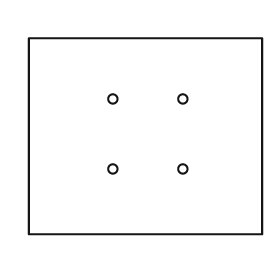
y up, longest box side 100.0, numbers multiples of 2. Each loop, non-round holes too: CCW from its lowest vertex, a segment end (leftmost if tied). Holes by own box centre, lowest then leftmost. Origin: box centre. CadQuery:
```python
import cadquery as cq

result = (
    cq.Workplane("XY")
    .moveTo(-50.0, -42.0)
    .lineTo(50.0, -42.0)
    .lineTo(50.0, 42.0)
    .lineTo(-50.0, 42.0)
    .close()
    .moveTo(-14.0, -14.0)
    .circle(2.0)
    .moveTo(16.0, -14.0)
    .circle(2.0)
    .moveTo(-14.0, 16.0)
    .circle(2.0)
    .moveTo(16.0, 16.0)
    .circle(2.0)
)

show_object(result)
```